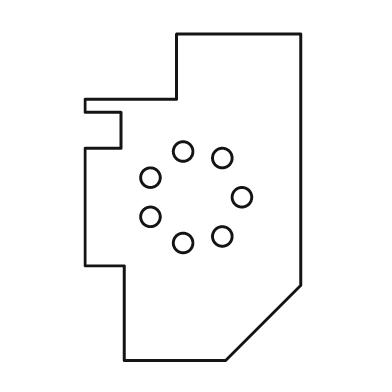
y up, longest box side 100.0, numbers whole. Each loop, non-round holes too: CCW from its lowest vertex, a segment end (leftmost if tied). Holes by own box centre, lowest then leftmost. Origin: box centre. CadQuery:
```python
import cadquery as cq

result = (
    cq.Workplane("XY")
    .moveTo(-21.0, -50.0)
    .lineTo(10.0, -50.0)
    .lineTo(33.0, -27.0)
    .lineTo(33.0, 50.0)
    .lineTo(-5.0, 50.0)
    .lineTo(-5.0, 30.0)
    .lineTo(-33.0, 30.0)
    .lineTo(-33.0, 26.0)
    .lineTo(-22.0, 26.0)
    .lineTo(-22.0, 15.0)
    .lineTo(-33.0, 15.0)
    .lineTo(-33.0, -21.0)
    .lineTo(-21.0, -21.0)
    .close()
    .moveTo(-3.0, -14.0)
    .circle(3.0)
    .moveTo(9.0, -12.0)
    .circle(3.0)
    .moveTo(-13.0, -6.0)
    .circle(3.0)
    .moveTo(15.0, 0.0)
    .circle(3.0)
    .moveTo(-13.0, 6.0)
    .circle(3.0)
    .moveTo(9.0, 12.0)
    .circle(3.0)
    .moveTo(-3.0, 14.0)
    .circle(3.0)
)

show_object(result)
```